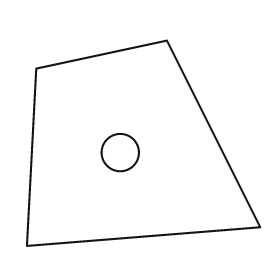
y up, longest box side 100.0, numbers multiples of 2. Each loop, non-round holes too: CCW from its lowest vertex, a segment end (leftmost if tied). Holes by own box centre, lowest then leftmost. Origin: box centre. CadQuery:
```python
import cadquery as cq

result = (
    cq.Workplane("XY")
    .moveTo(-50.0, -44.0)
    .lineTo(50.0, -36.0)
    .lineTo(10.0, 44.0)
    .lineTo(-46.0, 32.0)
    .close()
    .moveTo(-10.0, -4.0)
    .circle(8.0)
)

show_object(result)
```